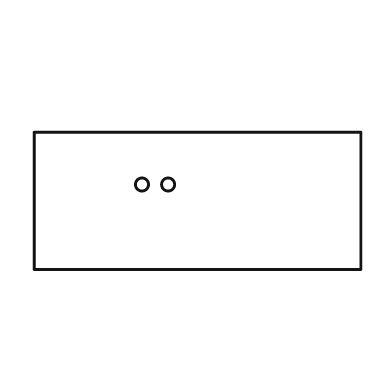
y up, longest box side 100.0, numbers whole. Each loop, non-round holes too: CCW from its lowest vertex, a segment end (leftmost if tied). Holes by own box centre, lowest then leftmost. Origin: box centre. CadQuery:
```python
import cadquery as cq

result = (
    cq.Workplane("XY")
    .moveTo(-50.0, -21.0)
    .lineTo(50.0, -21.0)
    .lineTo(50.0, 21.0)
    .lineTo(-50.0, 21.0)
    .close()
    .moveTo(-17.0, 5.0)
    .circle(2.0)
    .moveTo(-9.0, 5.0)
    .circle(2.0)
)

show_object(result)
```